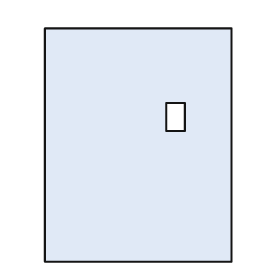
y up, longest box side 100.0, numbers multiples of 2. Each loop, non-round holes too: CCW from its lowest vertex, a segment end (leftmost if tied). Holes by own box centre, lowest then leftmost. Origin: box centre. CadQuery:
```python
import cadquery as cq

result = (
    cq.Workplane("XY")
    .moveTo(-40.0, -50.0)
    .lineTo(40.0, -50.0)
    .lineTo(40.0, 50.0)
    .lineTo(-40.0, 50.0)
    .close()
    .moveTo(12.0, 6.0)
    .lineTo(20.0, 6.0)
    .lineTo(20.0, 18.0)
    .lineTo(12.0, 18.0)
    .close()
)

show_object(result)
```